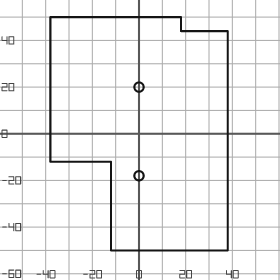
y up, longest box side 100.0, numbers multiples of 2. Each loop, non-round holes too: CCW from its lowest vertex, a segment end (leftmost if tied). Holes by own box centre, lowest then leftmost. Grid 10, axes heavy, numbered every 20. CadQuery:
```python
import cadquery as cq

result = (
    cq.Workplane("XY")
    .moveTo(-12.0, -50.0)
    .lineTo(38.0, -50.0)
    .lineTo(38.0, 44.0)
    .lineTo(18.0, 44.0)
    .lineTo(18.0, 50.0)
    .lineTo(-38.0, 50.0)
    .lineTo(-38.0, -12.0)
    .lineTo(-12.0, -12.0)
    .close()
    .moveTo(0.0, -18.0)
    .circle(2.0)
    .moveTo(0.0, 20.0)
    .circle(2.0)
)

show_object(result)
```